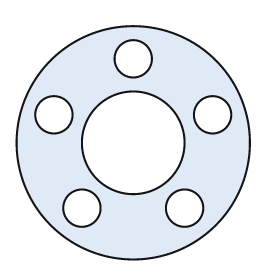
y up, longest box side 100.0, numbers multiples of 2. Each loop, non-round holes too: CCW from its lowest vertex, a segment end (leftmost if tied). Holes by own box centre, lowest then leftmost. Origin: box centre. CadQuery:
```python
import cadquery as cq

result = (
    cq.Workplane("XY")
    .moveTo(0.0, 0.0)
    .circle(50.0)
    .moveTo(-22.0, -28.0)
    .circle(8.0)
    .moveTo(22.0, -28.0)
    .circle(8.0)
    .moveTo(0.0, 0.0)
    .circle(22.0)
    .moveTo(-34.0, 12.0)
    .circle(8.0)
    .moveTo(34.0, 12.0)
    .circle(8.0)
    .moveTo(0.0, 36.0)
    .circle(8.0)
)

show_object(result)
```